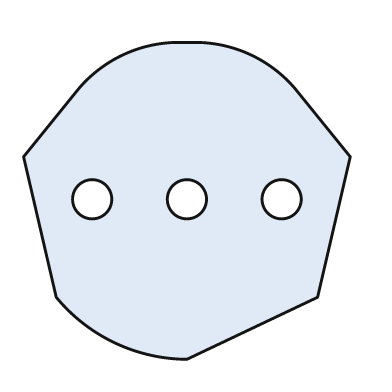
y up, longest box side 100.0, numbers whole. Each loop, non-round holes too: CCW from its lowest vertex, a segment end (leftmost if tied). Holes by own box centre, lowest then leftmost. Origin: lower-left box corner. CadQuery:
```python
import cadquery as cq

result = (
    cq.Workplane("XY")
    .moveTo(50.0, 0.0)
    .lineTo(90.0, 19.0)
    .lineTo(100.0, 62.0)
    .lineTo(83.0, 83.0)
    .threePointArc((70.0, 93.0), (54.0, 97.0))
    .lineTo(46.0, 97.0)
    .threePointArc((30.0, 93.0), (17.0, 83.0))
    .lineTo(0.0, 62.0)
    .lineTo(10.0, 19.0)
    .threePointArc((28.0, 5.0), (50.0, 0.0))
    .close()
    .moveTo(21.0, 49.0)
    .circle(6.0)
    .moveTo(50.0, 49.0)
    .circle(6.0)
    .moveTo(79.0, 49.0)
    .circle(6.0)
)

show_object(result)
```